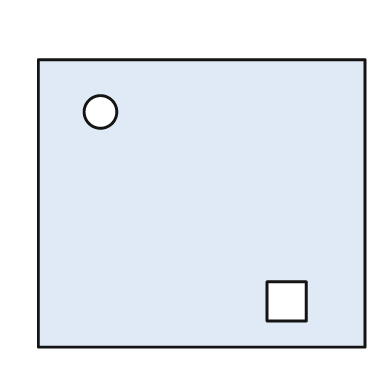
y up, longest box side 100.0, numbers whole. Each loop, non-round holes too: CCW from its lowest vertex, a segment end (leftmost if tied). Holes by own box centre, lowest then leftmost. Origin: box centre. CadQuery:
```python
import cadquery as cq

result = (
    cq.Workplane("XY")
    .moveTo(-50.0, -44.0)
    .lineTo(50.0, -44.0)
    .lineTo(50.0, 44.0)
    .lineTo(-50.0, 44.0)
    .close()
    .moveTo(20.0, -36.0)
    .lineTo(32.0, -36.0)
    .lineTo(32.0, -24.0)
    .lineTo(20.0, -24.0)
    .close()
    .moveTo(-31.0, 28.0)
    .circle(5.0)
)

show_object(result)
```